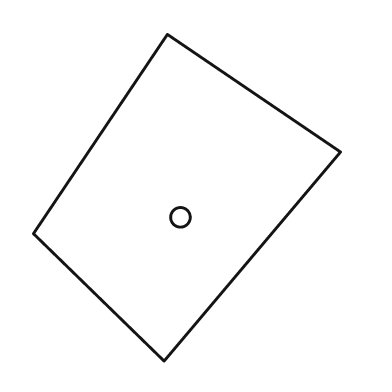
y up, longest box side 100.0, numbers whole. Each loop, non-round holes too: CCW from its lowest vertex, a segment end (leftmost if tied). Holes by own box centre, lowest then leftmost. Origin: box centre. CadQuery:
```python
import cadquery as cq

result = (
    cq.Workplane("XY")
    .moveTo(-7.0, -50.0)
    .lineTo(47.0, 14.0)
    .lineTo(-6.0, 50.0)
    .lineTo(-47.0, -11.0)
    .close()
    .moveTo(-2.0, -6.0)
    .circle(3.0)
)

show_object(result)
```